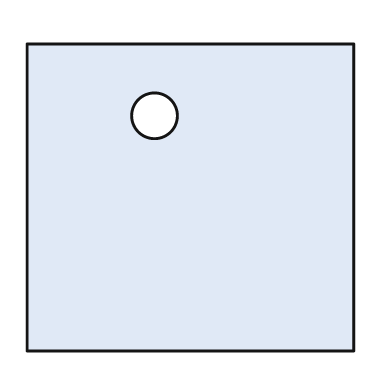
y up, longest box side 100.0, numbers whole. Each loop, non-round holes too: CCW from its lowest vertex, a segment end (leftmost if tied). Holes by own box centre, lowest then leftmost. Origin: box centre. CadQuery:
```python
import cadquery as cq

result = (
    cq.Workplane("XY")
    .moveTo(-50.0, -47.0)
    .lineTo(50.0, -47.0)
    .lineTo(50.0, 47.0)
    .lineTo(-50.0, 47.0)
    .close()
    .moveTo(-11.0, 25.0)
    .circle(7.0)
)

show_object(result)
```